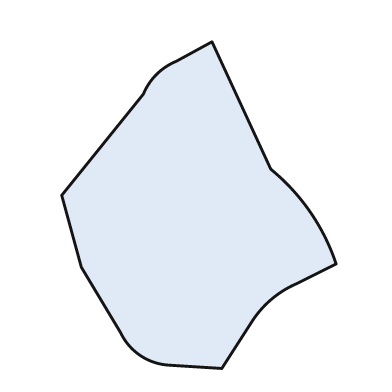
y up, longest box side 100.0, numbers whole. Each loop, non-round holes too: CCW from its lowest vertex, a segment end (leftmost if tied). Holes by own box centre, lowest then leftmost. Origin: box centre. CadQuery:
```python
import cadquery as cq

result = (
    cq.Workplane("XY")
    .moveTo(7.0, -50.0)
    .lineTo(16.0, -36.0)
    .threePointArc((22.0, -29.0), (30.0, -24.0))
    .lineTo(42.0, -18.0)
    .threePointArc((34.0, -2.0), (22.0, 11.0))
    .lineTo(4.0, 50.0)
    .lineTo(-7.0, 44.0)
    .threePointArc((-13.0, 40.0), (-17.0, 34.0))
    .lineTo(-42.0, 3.0)
    .lineTo(-36.0, -19.0)
    .lineTo(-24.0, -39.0)
    .threePointArc((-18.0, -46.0), (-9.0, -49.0))
    .close()
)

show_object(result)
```